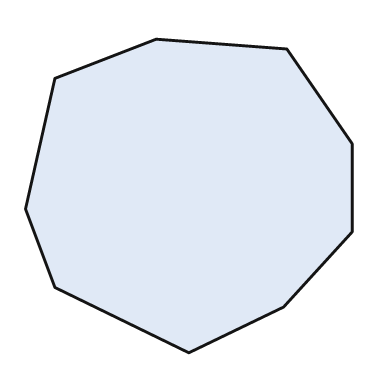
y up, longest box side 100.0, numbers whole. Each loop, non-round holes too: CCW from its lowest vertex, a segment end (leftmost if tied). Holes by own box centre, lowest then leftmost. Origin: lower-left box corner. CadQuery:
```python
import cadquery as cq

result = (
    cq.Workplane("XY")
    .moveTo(50.0, 0.0)
    .lineTo(79.0, 14.0)
    .lineTo(100.0, 37.0)
    .lineTo(100.0, 64.0)
    .lineTo(80.0, 93.0)
    .lineTo(40.0, 96.0)
    .lineTo(9.0, 84.0)
    .lineTo(0.0, 44.0)
    .lineTo(9.0, 20.0)
    .close()
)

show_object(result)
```